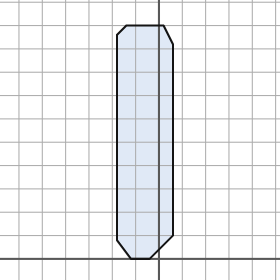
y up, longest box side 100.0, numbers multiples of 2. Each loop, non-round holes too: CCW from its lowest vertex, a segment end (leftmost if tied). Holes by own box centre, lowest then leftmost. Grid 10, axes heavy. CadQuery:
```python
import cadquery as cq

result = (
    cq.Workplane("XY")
    .moveTo(-12.0, 0.0)
    .lineTo(-4.0, 0.0)
    .lineTo(6.0, 10.0)
    .lineTo(6.0, 92.0)
    .lineTo(2.0, 100.0)
    .lineTo(-14.0, 100.0)
    .lineTo(-18.0, 96.0)
    .lineTo(-18.0, 8.0)
    .close()
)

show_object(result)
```